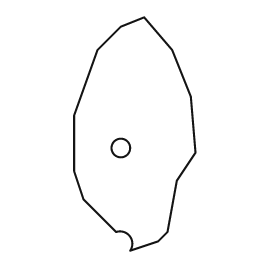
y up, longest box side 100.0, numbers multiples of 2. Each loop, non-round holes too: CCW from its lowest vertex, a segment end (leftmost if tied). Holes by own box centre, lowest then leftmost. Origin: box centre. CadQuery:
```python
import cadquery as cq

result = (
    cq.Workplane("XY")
    .moveTo(-2.0, -50.0)
    .lineTo(10.0, -46.0)
    .lineTo(14.0, -42.0)
    .lineTo(18.0, -20.0)
    .lineTo(26.0, -8.0)
    .lineTo(24.0, 16.0)
    .lineTo(16.0, 36.0)
    .lineTo(4.0, 50.0)
    .lineTo(-6.0, 46.0)
    .lineTo(-16.0, 36.0)
    .lineTo(-26.0, 8.0)
    .lineTo(-26.0, -16.0)
    .lineTo(-22.0, -28.0)
    .lineTo(-8.0, -42.0)
    .threePointArc((-2.0, -44.0), (-2.0, -50.0))
    .close()
    .moveTo(-6.0, -6.0)
    .circle(4.0)
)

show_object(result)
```